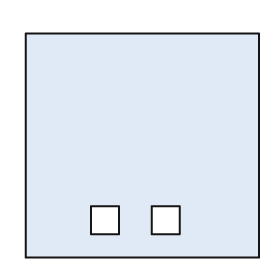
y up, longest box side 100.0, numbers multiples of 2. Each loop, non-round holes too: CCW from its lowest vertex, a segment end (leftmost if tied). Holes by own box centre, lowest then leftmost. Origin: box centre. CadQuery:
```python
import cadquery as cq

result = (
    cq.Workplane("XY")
    .moveTo(-50.0, -48.0)
    .lineTo(50.0, -48.0)
    .lineTo(50.0, 48.0)
    .lineTo(-50.0, 48.0)
    .close()
    .moveTo(-22.0, -38.0)
    .lineTo(-10.0, -38.0)
    .lineTo(-10.0, -26.0)
    .lineTo(-22.0, -26.0)
    .close()
    .moveTo(4.0, -38.0)
    .lineTo(16.0, -38.0)
    .lineTo(16.0, -26.0)
    .lineTo(4.0, -26.0)
    .close()
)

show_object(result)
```